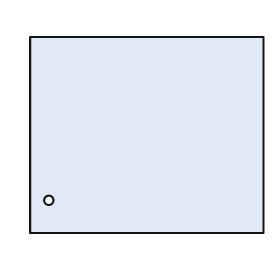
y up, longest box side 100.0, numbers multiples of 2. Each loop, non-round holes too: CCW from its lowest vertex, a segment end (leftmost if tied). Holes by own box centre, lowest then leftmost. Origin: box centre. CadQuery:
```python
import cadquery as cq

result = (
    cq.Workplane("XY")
    .moveTo(-50.0, -42.0)
    .lineTo(50.0, -42.0)
    .lineTo(50.0, 42.0)
    .lineTo(-50.0, 42.0)
    .close()
    .moveTo(-42.0, -28.0)
    .circle(2.0)
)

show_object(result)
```